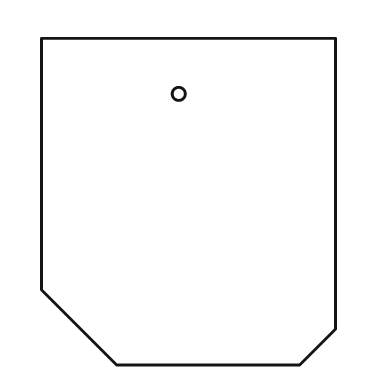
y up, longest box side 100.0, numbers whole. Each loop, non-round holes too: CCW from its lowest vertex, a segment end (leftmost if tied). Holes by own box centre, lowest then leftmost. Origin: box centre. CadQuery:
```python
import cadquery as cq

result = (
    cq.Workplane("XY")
    .moveTo(-22.0, -50.0)
    .lineTo(34.0, -50.0)
    .lineTo(45.0, -39.0)
    .lineTo(45.0, 50.0)
    .lineTo(-45.0, 50.0)
    .lineTo(-45.0, -27.0)
    .close()
    .moveTo(-3.0, 33.0)
    .circle(2.0)
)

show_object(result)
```